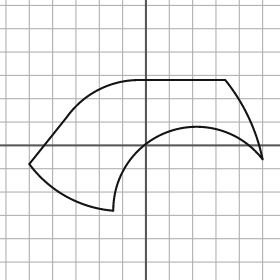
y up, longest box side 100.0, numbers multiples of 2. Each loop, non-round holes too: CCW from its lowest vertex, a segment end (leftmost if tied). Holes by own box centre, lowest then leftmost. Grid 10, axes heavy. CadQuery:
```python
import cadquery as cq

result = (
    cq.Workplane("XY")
    .moveTo(-14.0, -28.0)
    .threePointArc((10.0, 6.0), (50.0, -6.0))
    .threePointArc((44.0, 12.0), (34.0, 28.0))
    .lineTo(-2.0, 28.0)
    .threePointArc((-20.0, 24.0), (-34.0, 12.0))
    .lineTo(-50.0, -8.0)
    .threePointArc((-34.0, -22.0), (-14.0, -28.0))
    .close()
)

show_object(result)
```